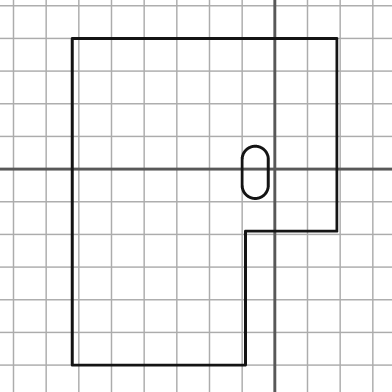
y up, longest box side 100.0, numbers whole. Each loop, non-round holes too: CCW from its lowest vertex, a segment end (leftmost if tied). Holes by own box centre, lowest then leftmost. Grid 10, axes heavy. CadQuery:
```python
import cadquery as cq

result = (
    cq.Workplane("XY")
    .moveTo(-62.0, -60.0)
    .lineTo(-9.0, -60.0)
    .lineTo(-9.0, -19.0)
    .lineTo(19.0, -19.0)
    .lineTo(19.0, 40.0)
    .lineTo(-62.0, 40.0)
    .close()
    .moveTo(-10.0, -5.0)
    .threePointArc((-6.0, -9.0), (-2.0, -5.0))
    .lineTo(-2.0, 3.0)
    .threePointArc((-6.0, 7.0), (-10.0, 3.0))
    .close()
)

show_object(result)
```